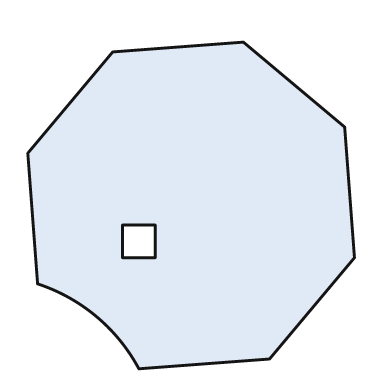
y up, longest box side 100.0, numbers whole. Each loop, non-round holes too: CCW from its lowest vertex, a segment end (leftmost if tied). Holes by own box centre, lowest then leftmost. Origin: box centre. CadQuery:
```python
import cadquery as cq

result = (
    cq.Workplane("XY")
    .moveTo(-16.0, -50.0)
    .lineTo(24.0, -47.0)
    .lineTo(50.0, -16.0)
    .lineTo(47.0, 24.0)
    .lineTo(16.0, 50.0)
    .lineTo(-24.0, 47.0)
    .lineTo(-50.0, 16.0)
    .lineTo(-47.0, -24.0)
    .threePointArc((-29.0, -34.0), (-16.0, -50.0))
    .close()
    .moveTo(-21.0, -16.0)
    .lineTo(-11.0, -16.0)
    .lineTo(-11.0, -6.0)
    .lineTo(-21.0, -6.0)
    .close()
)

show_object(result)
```